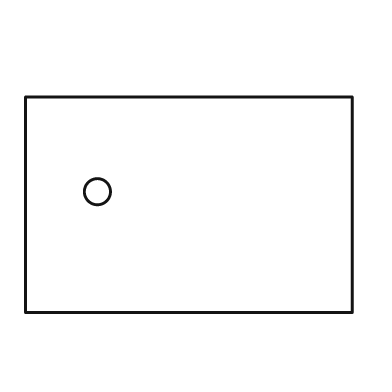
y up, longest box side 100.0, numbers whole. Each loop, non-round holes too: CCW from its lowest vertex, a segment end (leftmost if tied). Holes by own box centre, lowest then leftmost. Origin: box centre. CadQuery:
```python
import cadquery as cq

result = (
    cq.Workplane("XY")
    .moveTo(-50.0, -33.0)
    .lineTo(50.0, -33.0)
    .lineTo(50.0, 33.0)
    .lineTo(-50.0, 33.0)
    .close()
    .moveTo(-28.0, 4.0)
    .circle(4.0)
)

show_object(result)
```